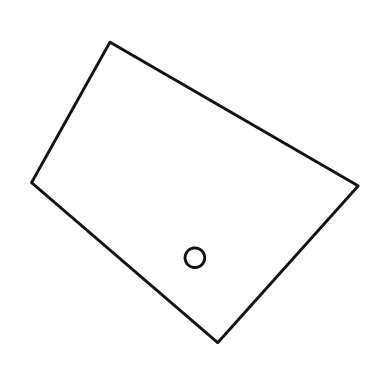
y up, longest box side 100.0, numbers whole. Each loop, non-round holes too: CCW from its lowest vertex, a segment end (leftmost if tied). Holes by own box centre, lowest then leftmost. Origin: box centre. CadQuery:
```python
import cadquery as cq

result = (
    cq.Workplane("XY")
    .moveTo(7.0, -46.0)
    .lineTo(50.0, 2.0)
    .lineTo(-26.0, 46.0)
    .lineTo(-50.0, 3.0)
    .close()
    .moveTo(0.0, -20.0)
    .circle(3.0)
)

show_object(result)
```